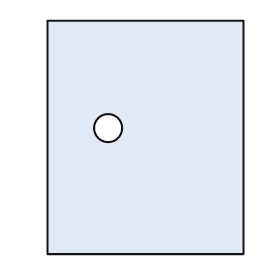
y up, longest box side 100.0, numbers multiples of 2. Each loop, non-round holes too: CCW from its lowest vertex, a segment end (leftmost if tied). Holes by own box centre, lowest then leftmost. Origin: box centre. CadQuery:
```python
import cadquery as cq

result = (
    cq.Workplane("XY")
    .moveTo(-42.0, -50.0)
    .lineTo(42.0, -50.0)
    .lineTo(42.0, 50.0)
    .lineTo(-42.0, 50.0)
    .close()
    .moveTo(-16.0, 4.0)
    .circle(6.0)
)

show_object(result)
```